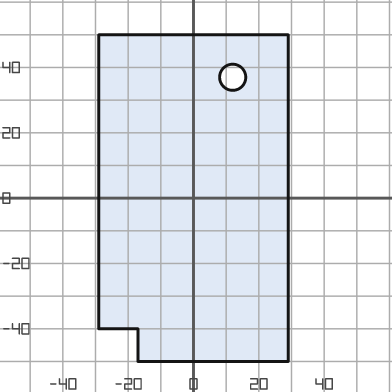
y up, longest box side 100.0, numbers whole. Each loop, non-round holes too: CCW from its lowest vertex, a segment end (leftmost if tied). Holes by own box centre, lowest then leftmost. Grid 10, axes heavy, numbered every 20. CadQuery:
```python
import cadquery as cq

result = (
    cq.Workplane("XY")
    .moveTo(-17.0, -50.0)
    .lineTo(29.0, -50.0)
    .lineTo(29.0, 50.0)
    .lineTo(-29.0, 50.0)
    .lineTo(-29.0, -40.0)
    .lineTo(-17.0, -40.0)
    .close()
    .moveTo(12.0, 37.0)
    .circle(4.0)
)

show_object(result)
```